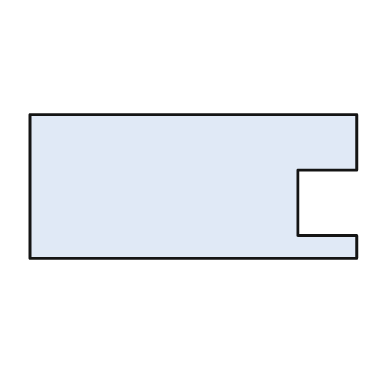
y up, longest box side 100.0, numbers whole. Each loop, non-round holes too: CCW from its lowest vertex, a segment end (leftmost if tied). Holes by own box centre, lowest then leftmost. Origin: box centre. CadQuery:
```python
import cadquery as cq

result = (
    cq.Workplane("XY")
    .moveTo(-50.0, -22.0)
    .lineTo(50.0, -22.0)
    .lineTo(50.0, -15.0)
    .lineTo(32.0, -15.0)
    .lineTo(32.0, 5.0)
    .lineTo(50.0, 5.0)
    .lineTo(50.0, 22.0)
    .lineTo(-50.0, 22.0)
    .close()
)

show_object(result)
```